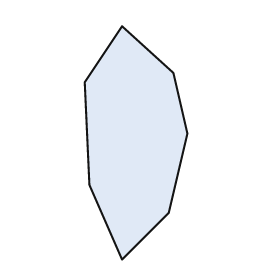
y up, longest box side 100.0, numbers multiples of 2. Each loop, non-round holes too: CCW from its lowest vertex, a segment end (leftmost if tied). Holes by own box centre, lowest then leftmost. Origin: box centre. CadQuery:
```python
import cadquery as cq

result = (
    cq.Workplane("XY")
    .moveTo(-6.0, -50.0)
    .lineTo(14.0, -30.0)
    .lineTo(22.0, 4.0)
    .lineTo(16.0, 30.0)
    .lineTo(-6.0, 50.0)
    .lineTo(-22.0, 26.0)
    .lineTo(-20.0, -18.0)
    .close()
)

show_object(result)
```